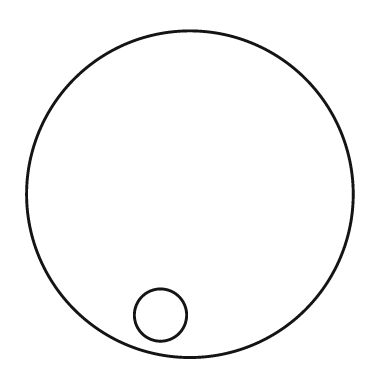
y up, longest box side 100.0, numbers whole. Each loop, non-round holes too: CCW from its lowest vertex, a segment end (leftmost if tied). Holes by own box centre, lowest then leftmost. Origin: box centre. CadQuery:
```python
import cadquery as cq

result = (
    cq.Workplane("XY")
    .moveTo(0.0, 0.0)
    .circle(50.0)
    .moveTo(-9.0, -37.0)
    .circle(8.0)
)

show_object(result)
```